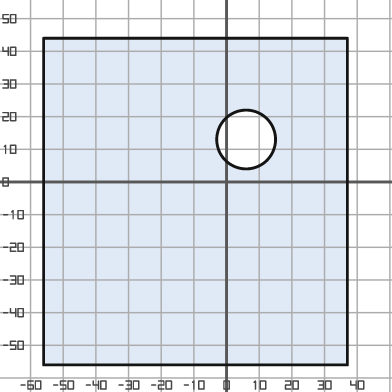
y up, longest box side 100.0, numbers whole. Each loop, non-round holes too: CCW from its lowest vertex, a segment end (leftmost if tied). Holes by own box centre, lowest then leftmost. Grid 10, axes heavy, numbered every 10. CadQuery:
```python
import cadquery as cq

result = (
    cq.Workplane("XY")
    .moveTo(-56.0, -56.0)
    .lineTo(37.0, -56.0)
    .lineTo(37.0, 44.0)
    .lineTo(-56.0, 44.0)
    .close()
    .moveTo(6.0, 13.0)
    .circle(9.0)
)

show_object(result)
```